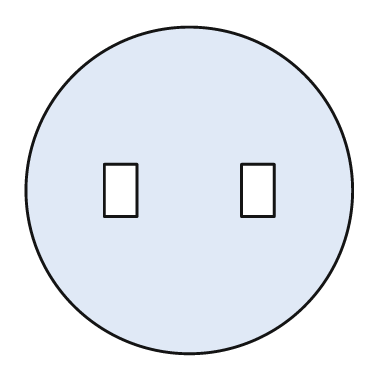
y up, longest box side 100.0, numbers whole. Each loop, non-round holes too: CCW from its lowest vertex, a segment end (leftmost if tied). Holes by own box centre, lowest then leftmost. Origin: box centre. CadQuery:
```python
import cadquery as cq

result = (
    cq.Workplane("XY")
    .moveTo(0.0, 0.0)
    .circle(50.0)
    .moveTo(-26.0, -8.0)
    .lineTo(-16.0, -8.0)
    .lineTo(-16.0, 8.0)
    .lineTo(-26.0, 8.0)
    .close()
    .moveTo(16.0, -8.0)
    .lineTo(26.0, -8.0)
    .lineTo(26.0, 8.0)
    .lineTo(16.0, 8.0)
    .close()
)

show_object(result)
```